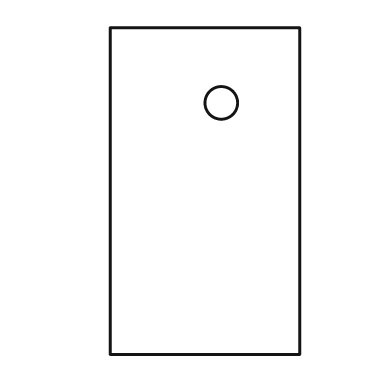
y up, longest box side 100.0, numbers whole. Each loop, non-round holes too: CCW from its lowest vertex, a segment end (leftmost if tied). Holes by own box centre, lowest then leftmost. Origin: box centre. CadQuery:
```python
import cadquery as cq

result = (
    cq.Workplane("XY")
    .moveTo(-29.0, -50.0)
    .lineTo(29.0, -50.0)
    .lineTo(29.0, 50.0)
    .lineTo(-29.0, 50.0)
    .close()
    .moveTo(5.0, 27.0)
    .circle(5.0)
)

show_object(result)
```